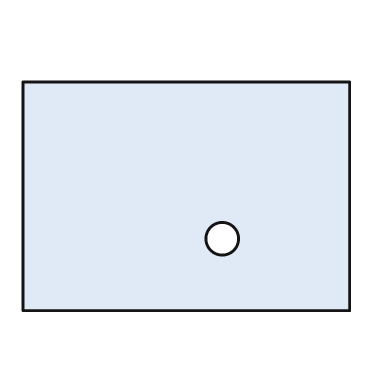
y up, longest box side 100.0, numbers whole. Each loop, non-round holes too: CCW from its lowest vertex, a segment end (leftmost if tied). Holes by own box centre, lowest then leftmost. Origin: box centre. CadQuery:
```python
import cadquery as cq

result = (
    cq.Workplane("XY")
    .moveTo(-50.0, -35.0)
    .lineTo(50.0, -35.0)
    .lineTo(50.0, 35.0)
    .lineTo(-50.0, 35.0)
    .close()
    .moveTo(11.0, -13.0)
    .circle(5.0)
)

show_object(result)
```